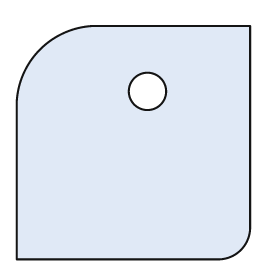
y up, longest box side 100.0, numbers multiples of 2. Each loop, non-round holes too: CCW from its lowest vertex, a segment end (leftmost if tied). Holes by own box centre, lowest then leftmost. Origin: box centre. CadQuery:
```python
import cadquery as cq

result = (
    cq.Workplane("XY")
    .moveTo(-50.0, -50.0)
    .lineTo(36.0, -50.0)
    .threePointArc((46.0, -46.0), (50.0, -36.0))
    .lineTo(50.0, 50.0)
    .lineTo(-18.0, 50.0)
    .threePointArc((-40.0, 40.0), (-50.0, 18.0))
    .close()
    .moveTo(6.0, 22.0)
    .circle(8.0)
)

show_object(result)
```